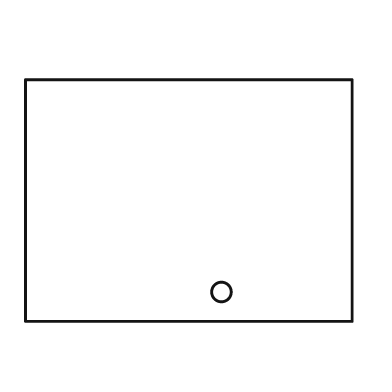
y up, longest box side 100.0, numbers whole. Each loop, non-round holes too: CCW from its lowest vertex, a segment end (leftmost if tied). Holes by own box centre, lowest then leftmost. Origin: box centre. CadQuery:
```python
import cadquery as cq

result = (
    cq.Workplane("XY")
    .moveTo(-50.0, -37.0)
    .lineTo(50.0, -37.0)
    .lineTo(50.0, 37.0)
    .lineTo(-50.0, 37.0)
    .close()
    .moveTo(10.0, -28.0)
    .circle(3.0)
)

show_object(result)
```